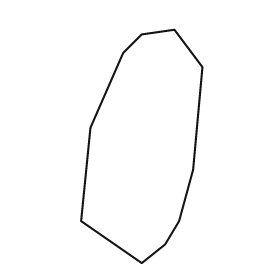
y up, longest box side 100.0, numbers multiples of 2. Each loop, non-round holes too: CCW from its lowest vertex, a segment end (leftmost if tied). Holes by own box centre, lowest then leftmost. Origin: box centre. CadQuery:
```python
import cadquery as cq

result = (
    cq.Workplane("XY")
    .moveTo(0.0, -50.0)
    .lineTo(10.0, -42.0)
    .lineTo(16.0, -32.0)
    .lineTo(22.0, -10.0)
    .lineTo(26.0, 34.0)
    .lineTo(14.0, 50.0)
    .lineTo(0.0, 48.0)
    .lineTo(-8.0, 40.0)
    .lineTo(-22.0, 8.0)
    .lineTo(-26.0, -32.0)
    .close()
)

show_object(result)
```